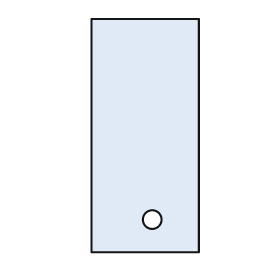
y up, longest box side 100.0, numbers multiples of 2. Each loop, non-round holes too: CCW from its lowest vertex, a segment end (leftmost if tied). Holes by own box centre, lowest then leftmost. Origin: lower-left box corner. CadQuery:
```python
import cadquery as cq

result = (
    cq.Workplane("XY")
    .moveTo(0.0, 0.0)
    .lineTo(46.0, 0.0)
    .lineTo(46.0, 100.0)
    .lineTo(0.0, 100.0)
    .close()
    .moveTo(26.0, 14.0)
    .circle(4.0)
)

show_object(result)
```